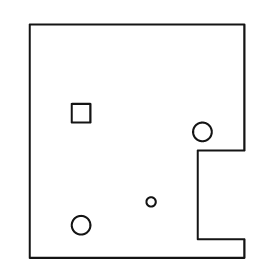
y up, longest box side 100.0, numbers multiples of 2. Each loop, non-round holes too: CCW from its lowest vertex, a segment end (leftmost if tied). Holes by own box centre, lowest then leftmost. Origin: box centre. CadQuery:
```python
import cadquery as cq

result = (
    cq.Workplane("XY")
    .moveTo(-46.0, -50.0)
    .lineTo(46.0, -50.0)
    .lineTo(46.0, -42.0)
    .lineTo(26.0, -42.0)
    .lineTo(26.0, -4.0)
    .lineTo(46.0, -4.0)
    .lineTo(46.0, 50.0)
    .lineTo(-46.0, 50.0)
    .close()
    .moveTo(-24.0, -36.0)
    .circle(4.0)
    .moveTo(6.0, -26.0)
    .circle(2.0)
    .moveTo(28.0, 4.0)
    .circle(4.0)
    .moveTo(-28.0, 8.0)
    .lineTo(-20.0, 8.0)
    .lineTo(-20.0, 16.0)
    .lineTo(-28.0, 16.0)
    .close()
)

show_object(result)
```